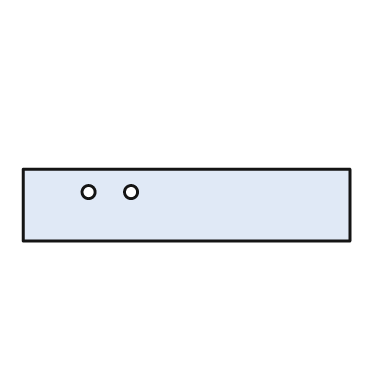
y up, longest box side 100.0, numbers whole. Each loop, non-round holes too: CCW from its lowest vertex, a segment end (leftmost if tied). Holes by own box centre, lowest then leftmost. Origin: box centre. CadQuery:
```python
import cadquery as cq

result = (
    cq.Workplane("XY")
    .moveTo(-50.0, -11.0)
    .lineTo(50.0, -11.0)
    .lineTo(50.0, 11.0)
    .lineTo(-50.0, 11.0)
    .close()
    .moveTo(-30.0, 4.0)
    .circle(2.0)
    .moveTo(-17.0, 4.0)
    .circle(2.0)
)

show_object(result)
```